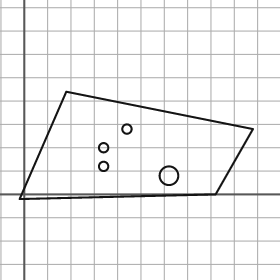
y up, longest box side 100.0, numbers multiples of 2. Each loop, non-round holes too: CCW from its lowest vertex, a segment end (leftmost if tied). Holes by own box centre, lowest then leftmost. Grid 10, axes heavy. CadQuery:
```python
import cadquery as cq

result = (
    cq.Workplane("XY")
    .moveTo(-2.0, -2.0)
    .lineTo(82.0, 0.0)
    .lineTo(98.0, 28.0)
    .lineTo(18.0, 44.0)
    .close()
    .moveTo(62.0, 8.0)
    .circle(4.0)
    .moveTo(34.0, 12.0)
    .circle(2.0)
    .moveTo(34.0, 20.0)
    .circle(2.0)
    .moveTo(44.0, 28.0)
    .circle(2.0)
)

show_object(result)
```